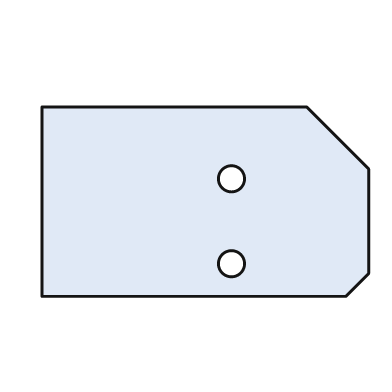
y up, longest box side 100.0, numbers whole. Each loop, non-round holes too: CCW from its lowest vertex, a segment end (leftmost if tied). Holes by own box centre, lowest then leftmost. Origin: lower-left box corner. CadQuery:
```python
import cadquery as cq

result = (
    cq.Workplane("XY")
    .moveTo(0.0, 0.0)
    .lineTo(93.0, 0.0)
    .lineTo(100.0, 7.0)
    .lineTo(100.0, 39.0)
    .lineTo(81.0, 58.0)
    .lineTo(0.0, 58.0)
    .close()
    .moveTo(58.0, 10.0)
    .circle(4.0)
    .moveTo(58.0, 36.0)
    .circle(4.0)
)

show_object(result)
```